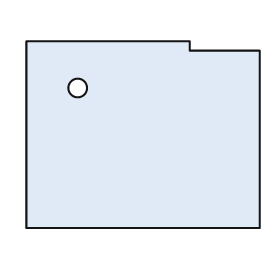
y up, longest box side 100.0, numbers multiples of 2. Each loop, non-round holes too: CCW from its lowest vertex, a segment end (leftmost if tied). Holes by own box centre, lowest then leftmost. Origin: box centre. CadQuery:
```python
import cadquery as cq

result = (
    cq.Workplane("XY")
    .moveTo(-50.0, -40.0)
    .lineTo(50.0, -40.0)
    .lineTo(50.0, 36.0)
    .lineTo(20.0, 36.0)
    .lineTo(20.0, 40.0)
    .lineTo(-50.0, 40.0)
    .close()
    .moveTo(-28.0, 20.0)
    .circle(4.0)
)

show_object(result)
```